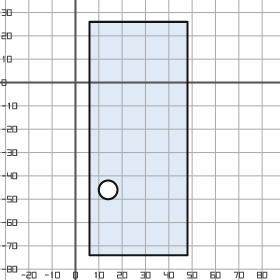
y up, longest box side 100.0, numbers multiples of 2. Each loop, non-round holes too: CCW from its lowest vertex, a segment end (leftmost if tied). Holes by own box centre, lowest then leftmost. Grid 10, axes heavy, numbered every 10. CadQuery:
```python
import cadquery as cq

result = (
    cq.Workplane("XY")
    .moveTo(6.0, -74.0)
    .lineTo(48.0, -74.0)
    .lineTo(48.0, 26.0)
    .lineTo(6.0, 26.0)
    .close()
    .moveTo(14.0, -46.0)
    .circle(4.0)
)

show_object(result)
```